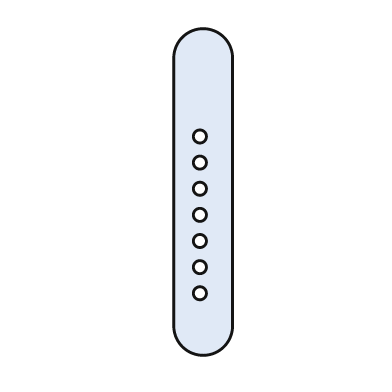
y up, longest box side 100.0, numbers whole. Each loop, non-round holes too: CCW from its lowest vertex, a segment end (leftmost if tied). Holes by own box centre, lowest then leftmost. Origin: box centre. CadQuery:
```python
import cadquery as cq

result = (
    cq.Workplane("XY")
    .moveTo(-9.0, -41.0)
    .threePointArc((0.0, -50.0), (9.0, -41.0))
    .lineTo(9.0, 41.0)
    .threePointArc((0.0, 50.0), (-9.0, 41.0))
    .close()
    .moveTo(-1.0, -31.0)
    .circle(2.0)
    .moveTo(-1.0, -23.0)
    .circle(2.0)
    .moveTo(-1.0, -15.0)
    .circle(2.0)
    .moveTo(-1.0, -7.0)
    .circle(2.0)
    .moveTo(-1.0, 1.0)
    .circle(2.0)
    .moveTo(-1.0, 9.0)
    .circle(2.0)
    .moveTo(-1.0, 17.0)
    .circle(2.0)
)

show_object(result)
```